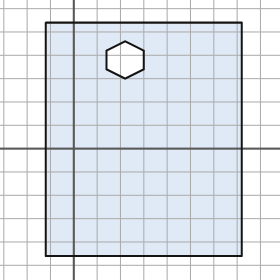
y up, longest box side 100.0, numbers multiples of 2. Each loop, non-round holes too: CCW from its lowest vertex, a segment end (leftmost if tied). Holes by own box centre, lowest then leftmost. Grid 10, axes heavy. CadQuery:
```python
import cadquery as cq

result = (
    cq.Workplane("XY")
    .moveTo(-12.0, -46.0)
    .lineTo(72.0, -46.0)
    .lineTo(72.0, 54.0)
    .lineTo(-12.0, 54.0)
    .close()
    .moveTo(22.0, 30.0)
    .lineTo(30.0, 34.0)
    .lineTo(30.0, 42.0)
    .lineTo(22.0, 46.0)
    .lineTo(14.0, 42.0)
    .lineTo(14.0, 34.0)
    .close()
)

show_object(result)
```